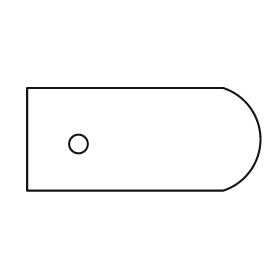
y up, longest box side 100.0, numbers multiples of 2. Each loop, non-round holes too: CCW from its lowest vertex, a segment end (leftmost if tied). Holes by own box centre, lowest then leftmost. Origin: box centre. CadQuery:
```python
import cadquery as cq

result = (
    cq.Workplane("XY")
    .moveTo(-50.0, -22.0)
    .lineTo(34.0, -22.0)
    .threePointArc((50.0, 0.0), (34.0, 22.0))
    .lineTo(-50.0, 22.0)
    .close()
    .moveTo(-28.0, -2.0)
    .circle(4.0)
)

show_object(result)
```